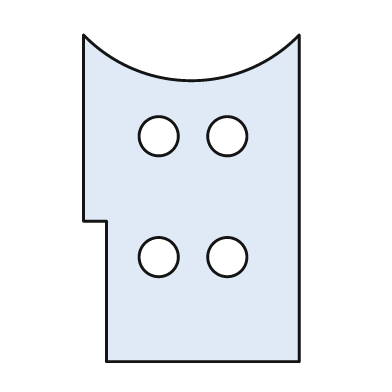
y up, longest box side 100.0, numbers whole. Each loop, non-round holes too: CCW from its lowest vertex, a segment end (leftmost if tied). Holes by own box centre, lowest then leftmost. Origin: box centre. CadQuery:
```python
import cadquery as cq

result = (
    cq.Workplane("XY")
    .moveTo(-26.0, -50.0)
    .lineTo(33.0, -50.0)
    .lineTo(33.0, 50.0)
    .threePointArc((0.0, 36.0), (-33.0, 50.0))
    .lineTo(-33.0, -7.0)
    .lineTo(-26.0, -7.0)
    .close()
    .moveTo(-10.0, -18.0)
    .circle(6.0)
    .moveTo(11.0, -18.0)
    .circle(6.0)
    .moveTo(-10.0, 19.0)
    .circle(6.0)
    .moveTo(11.0, 19.0)
    .circle(6.0)
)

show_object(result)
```